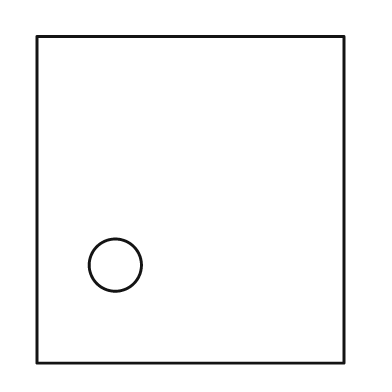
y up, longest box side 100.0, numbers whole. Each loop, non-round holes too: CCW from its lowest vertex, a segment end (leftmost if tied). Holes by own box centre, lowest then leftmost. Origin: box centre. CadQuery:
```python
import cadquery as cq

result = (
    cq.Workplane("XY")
    .moveTo(-47.0, -50.0)
    .lineTo(47.0, -50.0)
    .lineTo(47.0, 50.0)
    .lineTo(-47.0, 50.0)
    .close()
    .moveTo(-23.0, -20.0)
    .circle(8.0)
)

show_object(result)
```